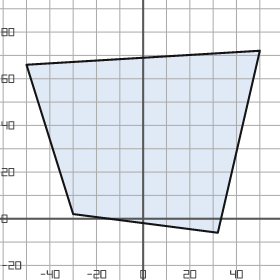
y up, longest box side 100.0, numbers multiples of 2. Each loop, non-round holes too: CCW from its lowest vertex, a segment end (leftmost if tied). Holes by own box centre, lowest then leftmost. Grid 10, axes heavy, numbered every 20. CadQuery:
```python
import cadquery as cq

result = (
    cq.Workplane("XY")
    .moveTo(32.0, -6.0)
    .lineTo(50.0, 72.0)
    .lineTo(-50.0, 66.0)
    .lineTo(-30.0, 2.0)
    .close()
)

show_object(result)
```